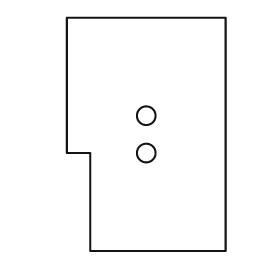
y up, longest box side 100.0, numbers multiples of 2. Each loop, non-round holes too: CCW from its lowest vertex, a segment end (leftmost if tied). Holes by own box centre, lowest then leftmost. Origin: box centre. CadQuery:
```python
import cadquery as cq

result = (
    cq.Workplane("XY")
    .moveTo(-24.0, -50.0)
    .lineTo(34.0, -50.0)
    .lineTo(34.0, 50.0)
    .lineTo(-34.0, 50.0)
    .lineTo(-34.0, -8.0)
    .lineTo(-24.0, -8.0)
    .close()
    .moveTo(0.0, -8.0)
    .circle(4.0)
    .moveTo(0.0, 8.0)
    .circle(4.0)
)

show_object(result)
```